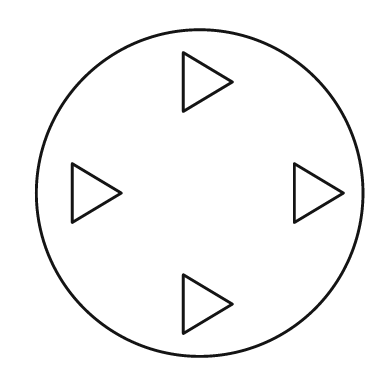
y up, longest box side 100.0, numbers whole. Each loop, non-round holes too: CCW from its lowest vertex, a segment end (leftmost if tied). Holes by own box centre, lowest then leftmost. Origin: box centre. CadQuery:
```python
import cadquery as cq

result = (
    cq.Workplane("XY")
    .moveTo(0.0, 0.0)
    .circle(50.0)
    .moveTo(-5.0, -43.0)
    .lineTo(10.0, -34.0)
    .lineTo(-5.0, -25.0)
    .close()
    .moveTo(-39.0, -9.0)
    .lineTo(-24.0, 0.0)
    .lineTo(-39.0, 9.0)
    .close()
    .moveTo(29.0, -9.0)
    .lineTo(44.0, 0.0)
    .lineTo(29.0, 9.0)
    .close()
    .moveTo(-5.0, 25.0)
    .lineTo(10.0, 34.0)
    .lineTo(-5.0, 43.0)
    .close()
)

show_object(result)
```